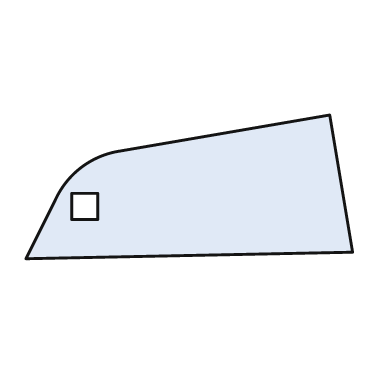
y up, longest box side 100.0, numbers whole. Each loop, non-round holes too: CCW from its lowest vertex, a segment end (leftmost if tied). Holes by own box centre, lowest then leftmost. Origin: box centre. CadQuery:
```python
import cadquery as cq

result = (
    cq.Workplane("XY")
    .moveTo(-50.0, -22.0)
    .lineTo(50.0, -20.0)
    .lineTo(43.0, 22.0)
    .lineTo(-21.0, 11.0)
    .threePointArc((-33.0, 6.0), (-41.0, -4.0))
    .close()
    .moveTo(-36.0, -10.0)
    .lineTo(-28.0, -10.0)
    .lineTo(-28.0, -2.0)
    .lineTo(-36.0, -2.0)
    .close()
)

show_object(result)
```